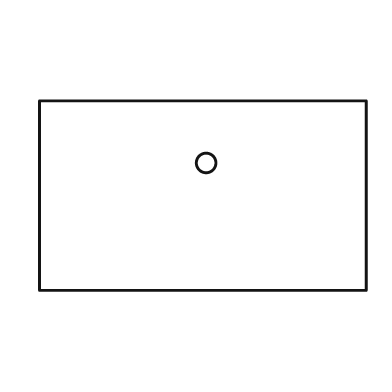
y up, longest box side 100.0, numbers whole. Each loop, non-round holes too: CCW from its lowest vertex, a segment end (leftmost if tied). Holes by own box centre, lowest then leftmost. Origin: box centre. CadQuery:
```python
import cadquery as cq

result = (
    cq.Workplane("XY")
    .moveTo(-50.0, -29.0)
    .lineTo(50.0, -29.0)
    .lineTo(50.0, 29.0)
    .lineTo(-50.0, 29.0)
    .close()
    .moveTo(1.0, 10.0)
    .circle(3.0)
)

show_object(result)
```